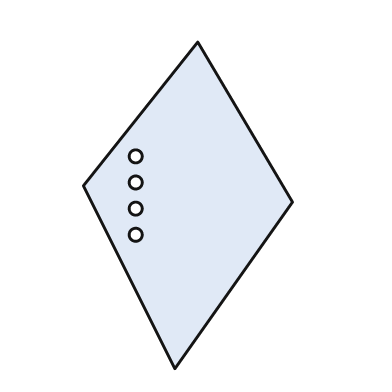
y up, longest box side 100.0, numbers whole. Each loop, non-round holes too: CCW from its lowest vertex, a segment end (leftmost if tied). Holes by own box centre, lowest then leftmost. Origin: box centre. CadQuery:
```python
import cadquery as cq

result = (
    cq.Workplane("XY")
    .moveTo(-4.0, -50.0)
    .lineTo(32.0, 1.0)
    .lineTo(3.0, 50.0)
    .lineTo(-32.0, 6.0)
    .close()
    .moveTo(-16.0, -9.0)
    .circle(2.0)
    .moveTo(-16.0, -1.0)
    .circle(2.0)
    .moveTo(-16.0, 7.0)
    .circle(2.0)
    .moveTo(-16.0, 15.0)
    .circle(2.0)
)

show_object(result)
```